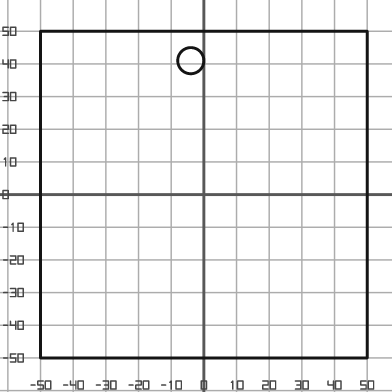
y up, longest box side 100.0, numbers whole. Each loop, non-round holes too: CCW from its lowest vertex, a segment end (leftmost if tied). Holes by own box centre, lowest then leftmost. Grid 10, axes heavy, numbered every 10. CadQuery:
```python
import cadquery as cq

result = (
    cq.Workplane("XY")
    .moveTo(-50.0, -50.0)
    .lineTo(50.0, -50.0)
    .lineTo(50.0, 50.0)
    .lineTo(-50.0, 50.0)
    .close()
    .moveTo(-4.0, 41.0)
    .circle(4.0)
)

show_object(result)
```